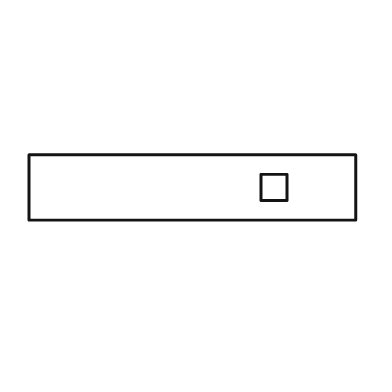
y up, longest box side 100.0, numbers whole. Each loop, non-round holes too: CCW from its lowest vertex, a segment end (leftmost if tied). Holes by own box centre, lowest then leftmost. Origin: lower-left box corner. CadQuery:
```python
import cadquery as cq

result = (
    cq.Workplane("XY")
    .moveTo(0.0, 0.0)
    .lineTo(100.0, 0.0)
    .lineTo(100.0, 20.0)
    .lineTo(0.0, 20.0)
    .close()
    .moveTo(71.0, 6.0)
    .lineTo(79.0, 6.0)
    .lineTo(79.0, 14.0)
    .lineTo(71.0, 14.0)
    .close()
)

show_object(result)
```